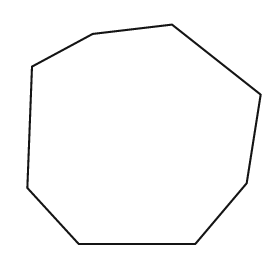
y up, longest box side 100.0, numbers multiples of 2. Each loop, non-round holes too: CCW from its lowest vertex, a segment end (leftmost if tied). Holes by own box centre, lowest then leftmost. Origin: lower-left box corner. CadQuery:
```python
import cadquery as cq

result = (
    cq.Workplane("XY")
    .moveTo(22.0, 0.0)
    .lineTo(72.0, 0.0)
    .lineTo(94.0, 26.0)
    .lineTo(100.0, 64.0)
    .lineTo(62.0, 94.0)
    .lineTo(28.0, 90.0)
    .lineTo(2.0, 76.0)
    .lineTo(0.0, 24.0)
    .close()
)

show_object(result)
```